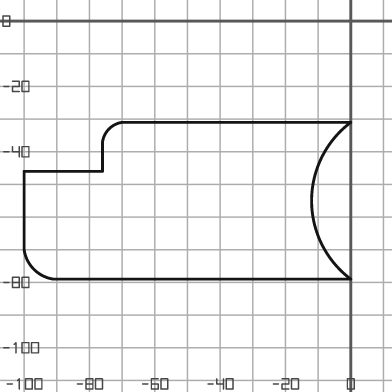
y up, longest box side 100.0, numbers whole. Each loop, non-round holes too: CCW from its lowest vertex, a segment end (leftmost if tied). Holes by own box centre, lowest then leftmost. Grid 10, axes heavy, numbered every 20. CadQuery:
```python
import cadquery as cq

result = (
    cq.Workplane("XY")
    .moveTo(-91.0, -79.0)
    .lineTo(0.0, -79.0)
    .threePointArc((-12.0, -55.0), (0.0, -31.0))
    .lineTo(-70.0, -31.0)
    .threePointArc((-74.0, -33.0), (-76.0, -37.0))
    .lineTo(-76.0, -46.0)
    .lineTo(-100.0, -46.0)
    .lineTo(-100.0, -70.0)
    .threePointArc((-97.0, -76.0), (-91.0, -79.0))
    .close()
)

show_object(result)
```